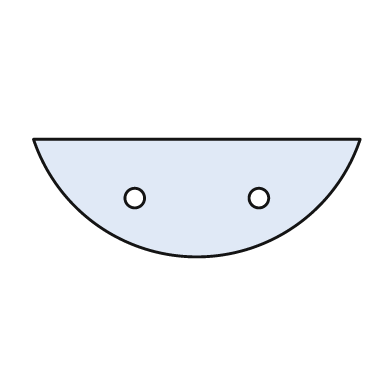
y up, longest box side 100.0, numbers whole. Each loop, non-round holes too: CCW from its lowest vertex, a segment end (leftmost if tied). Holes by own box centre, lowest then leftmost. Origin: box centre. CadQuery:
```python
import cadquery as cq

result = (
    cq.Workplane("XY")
    .moveTo(-50.0, 18.0)
    .threePointArc((0.0, -18.0), (50.0, 18.0))
    .close()
    .moveTo(-19.0, 0.0)
    .circle(3.0)
    .moveTo(19.0, 0.0)
    .circle(3.0)
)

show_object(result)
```